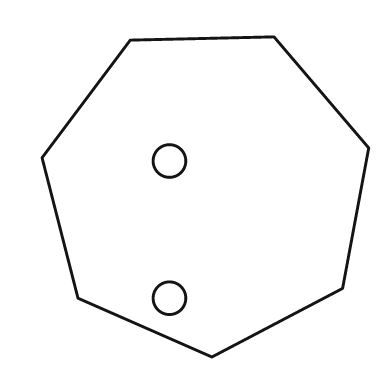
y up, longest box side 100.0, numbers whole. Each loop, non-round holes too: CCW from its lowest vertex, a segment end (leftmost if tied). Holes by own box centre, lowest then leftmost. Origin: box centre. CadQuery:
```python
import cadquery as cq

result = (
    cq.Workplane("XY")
    .moveTo(2.0, -49.0)
    .lineTo(42.0, -28.0)
    .lineTo(50.0, 15.0)
    .lineTo(21.0, 49.0)
    .lineTo(-23.0, 48.0)
    .lineTo(-50.0, 12.0)
    .lineTo(-39.0, -31.0)
    .close()
    .moveTo(-11.0, -31.0)
    .circle(5.0)
    .moveTo(-11.0, 11.0)
    .circle(5.0)
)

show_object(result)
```